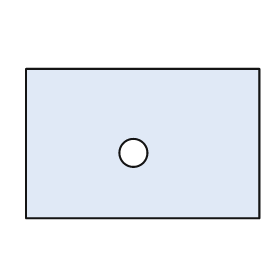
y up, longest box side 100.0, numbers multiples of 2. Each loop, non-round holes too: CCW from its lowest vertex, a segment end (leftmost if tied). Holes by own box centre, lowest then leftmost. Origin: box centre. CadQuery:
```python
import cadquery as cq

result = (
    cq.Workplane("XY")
    .moveTo(-50.0, -32.0)
    .lineTo(50.0, -32.0)
    .lineTo(50.0, 32.0)
    .lineTo(-50.0, 32.0)
    .close()
    .moveTo(-4.0, -4.0)
    .circle(6.0)
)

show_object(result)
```